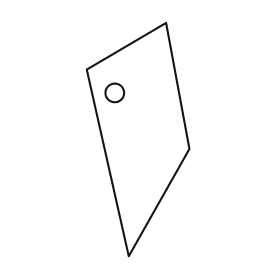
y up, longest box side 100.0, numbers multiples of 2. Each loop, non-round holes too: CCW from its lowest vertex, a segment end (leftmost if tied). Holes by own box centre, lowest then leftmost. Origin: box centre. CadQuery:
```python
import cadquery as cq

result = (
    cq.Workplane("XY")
    .moveTo(-4.0, -50.0)
    .lineTo(22.0, -4.0)
    .lineTo(12.0, 50.0)
    .lineTo(-22.0, 30.0)
    .close()
    .moveTo(-10.0, 20.0)
    .circle(4.0)
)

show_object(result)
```